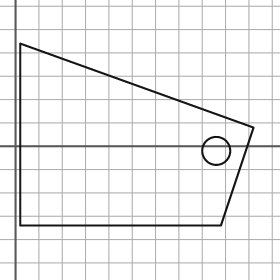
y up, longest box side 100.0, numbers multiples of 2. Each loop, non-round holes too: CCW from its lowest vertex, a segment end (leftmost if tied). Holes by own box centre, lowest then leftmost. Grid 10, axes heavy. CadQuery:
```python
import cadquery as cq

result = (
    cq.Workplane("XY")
    .moveTo(2.0, -34.0)
    .lineTo(88.0, -34.0)
    .lineTo(102.0, 8.0)
    .lineTo(2.0, 44.0)
    .close()
    .moveTo(86.0, -2.0)
    .circle(6.0)
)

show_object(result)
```